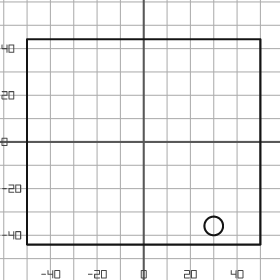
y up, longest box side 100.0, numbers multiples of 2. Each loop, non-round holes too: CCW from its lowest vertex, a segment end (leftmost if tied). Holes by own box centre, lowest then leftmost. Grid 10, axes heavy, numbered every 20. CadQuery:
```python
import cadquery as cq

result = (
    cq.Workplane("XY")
    .moveTo(-50.0, -44.0)
    .lineTo(50.0, -44.0)
    .lineTo(50.0, 44.0)
    .lineTo(-50.0, 44.0)
    .close()
    .moveTo(30.0, -36.0)
    .circle(4.0)
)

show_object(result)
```